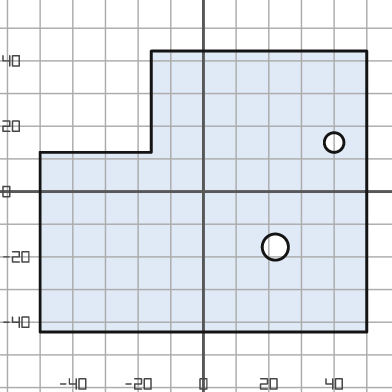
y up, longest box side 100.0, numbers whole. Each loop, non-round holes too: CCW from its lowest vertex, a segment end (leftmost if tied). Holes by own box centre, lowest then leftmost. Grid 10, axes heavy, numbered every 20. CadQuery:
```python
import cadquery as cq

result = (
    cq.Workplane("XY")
    .moveTo(-50.0, -43.0)
    .lineTo(50.0, -43.0)
    .lineTo(50.0, 43.0)
    .lineTo(-16.0, 43.0)
    .lineTo(-16.0, 12.0)
    .lineTo(-50.0, 12.0)
    .close()
    .moveTo(22.0, -17.0)
    .circle(4.0)
    .moveTo(40.0, 15.0)
    .circle(3.0)
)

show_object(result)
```